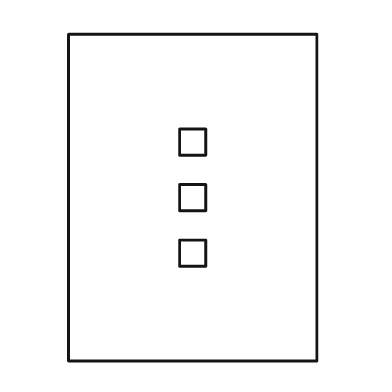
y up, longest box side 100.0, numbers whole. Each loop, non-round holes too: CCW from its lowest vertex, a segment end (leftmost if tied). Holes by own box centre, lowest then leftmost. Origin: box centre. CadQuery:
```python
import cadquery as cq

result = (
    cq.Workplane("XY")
    .moveTo(-38.0, -50.0)
    .lineTo(38.0, -50.0)
    .lineTo(38.0, 50.0)
    .lineTo(-38.0, 50.0)
    .close()
    .moveTo(-4.0, -21.0)
    .lineTo(4.0, -21.0)
    .lineTo(4.0, -13.0)
    .lineTo(-4.0, -13.0)
    .close()
    .moveTo(-4.0, -4.0)
    .lineTo(4.0, -4.0)
    .lineTo(4.0, 4.0)
    .lineTo(-4.0, 4.0)
    .close()
    .moveTo(-4.0, 13.0)
    .lineTo(4.0, 13.0)
    .lineTo(4.0, 21.0)
    .lineTo(-4.0, 21.0)
    .close()
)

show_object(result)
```